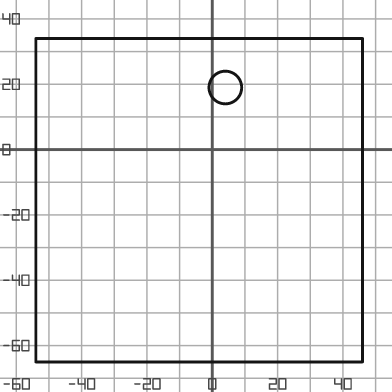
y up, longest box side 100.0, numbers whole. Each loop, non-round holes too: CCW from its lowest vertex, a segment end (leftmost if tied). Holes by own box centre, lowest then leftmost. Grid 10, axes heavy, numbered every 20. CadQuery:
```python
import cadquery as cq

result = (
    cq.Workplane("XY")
    .moveTo(-54.0, -65.0)
    .lineTo(46.0, -65.0)
    .lineTo(46.0, 34.0)
    .lineTo(-54.0, 34.0)
    .close()
    .moveTo(4.0, 19.0)
    .circle(5.0)
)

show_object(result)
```